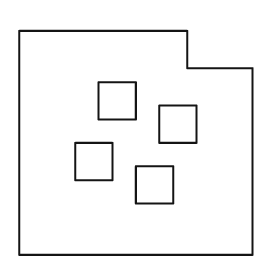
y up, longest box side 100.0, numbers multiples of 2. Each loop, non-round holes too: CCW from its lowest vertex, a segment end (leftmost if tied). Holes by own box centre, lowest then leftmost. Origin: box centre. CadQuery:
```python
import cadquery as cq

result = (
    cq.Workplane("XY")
    .moveTo(-50.0, -48.0)
    .lineTo(50.0, -48.0)
    .lineTo(50.0, 32.0)
    .lineTo(22.0, 32.0)
    .lineTo(22.0, 48.0)
    .lineTo(-50.0, 48.0)
    .close()
    .moveTo(0.0, -26.0)
    .lineTo(16.0, -26.0)
    .lineTo(16.0, -10.0)
    .lineTo(0.0, -10.0)
    .close()
    .moveTo(-26.0, -16.0)
    .lineTo(-10.0, -16.0)
    .lineTo(-10.0, 0.0)
    .lineTo(-26.0, 0.0)
    .close()
    .moveTo(10.0, 0.0)
    .lineTo(26.0, 0.0)
    .lineTo(26.0, 16.0)
    .lineTo(10.0, 16.0)
    .close()
    .moveTo(-16.0, 10.0)
    .lineTo(0.0, 10.0)
    .lineTo(0.0, 26.0)
    .lineTo(-16.0, 26.0)
    .close()
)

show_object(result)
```